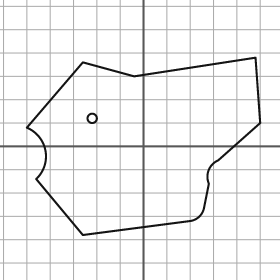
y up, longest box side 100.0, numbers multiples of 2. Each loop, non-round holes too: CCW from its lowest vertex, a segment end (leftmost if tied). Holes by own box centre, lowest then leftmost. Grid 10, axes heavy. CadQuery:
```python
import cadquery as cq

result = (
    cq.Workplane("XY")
    .moveTo(-26.0, -38.0)
    .lineTo(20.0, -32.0)
    .threePointArc((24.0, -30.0), (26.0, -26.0))
    .lineTo(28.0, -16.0)
    .threePointArc((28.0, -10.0), (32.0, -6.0))
    .lineTo(50.0, 10.0)
    .lineTo(48.0, 38.0)
    .lineTo(-4.0, 30.0)
    .lineTo(-26.0, 36.0)
    .lineTo(-50.0, 8.0)
    .threePointArc((-42.0, -2.0), (-46.0, -14.0))
    .close()
    .moveTo(-22.0, 12.0)
    .circle(2.0)
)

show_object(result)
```